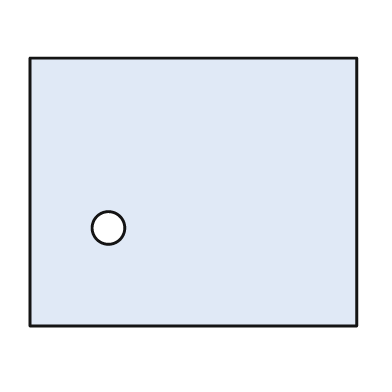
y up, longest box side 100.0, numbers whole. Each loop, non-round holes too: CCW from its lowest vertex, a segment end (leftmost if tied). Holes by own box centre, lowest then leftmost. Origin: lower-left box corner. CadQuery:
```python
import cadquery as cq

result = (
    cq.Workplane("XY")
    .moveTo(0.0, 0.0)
    .lineTo(100.0, 0.0)
    .lineTo(100.0, 82.0)
    .lineTo(0.0, 82.0)
    .close()
    .moveTo(24.0, 30.0)
    .circle(5.0)
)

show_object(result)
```